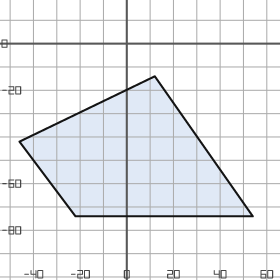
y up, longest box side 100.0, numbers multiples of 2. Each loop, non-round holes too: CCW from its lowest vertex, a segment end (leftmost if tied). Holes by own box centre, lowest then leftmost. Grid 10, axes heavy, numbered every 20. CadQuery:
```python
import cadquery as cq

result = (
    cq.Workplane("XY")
    .moveTo(-22.0, -74.0)
    .lineTo(54.0, -74.0)
    .lineTo(12.0, -14.0)
    .lineTo(-46.0, -42.0)
    .close()
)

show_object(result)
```